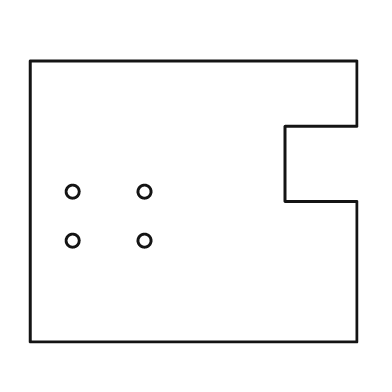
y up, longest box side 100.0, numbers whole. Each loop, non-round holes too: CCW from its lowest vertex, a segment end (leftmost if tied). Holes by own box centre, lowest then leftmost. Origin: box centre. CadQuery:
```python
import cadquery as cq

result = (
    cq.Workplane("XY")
    .moveTo(-50.0, -43.0)
    .lineTo(50.0, -43.0)
    .lineTo(50.0, 0.0)
    .lineTo(28.0, 0.0)
    .lineTo(28.0, 23.0)
    .lineTo(50.0, 23.0)
    .lineTo(50.0, 43.0)
    .lineTo(-50.0, 43.0)
    .close()
    .moveTo(-37.0, -12.0)
    .circle(2.0)
    .moveTo(-15.0, -12.0)
    .circle(2.0)
    .moveTo(-37.0, 3.0)
    .circle(2.0)
    .moveTo(-15.0, 3.0)
    .circle(2.0)
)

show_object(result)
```